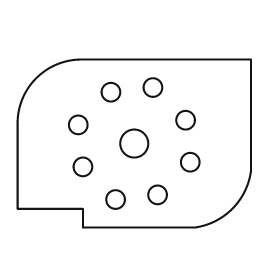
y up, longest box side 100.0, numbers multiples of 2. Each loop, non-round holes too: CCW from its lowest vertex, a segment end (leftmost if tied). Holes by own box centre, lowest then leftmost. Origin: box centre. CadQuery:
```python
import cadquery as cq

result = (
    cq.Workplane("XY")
    .moveTo(-22.0, -36.0)
    .lineTo(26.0, -36.0)
    .threePointArc((42.0, -28.0), (50.0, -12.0))
    .lineTo(50.0, 36.0)
    .lineTo(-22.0, 36.0)
    .threePointArc((-42.0, 28.0), (-50.0, 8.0))
    .lineTo(-50.0, -28.0)
    .lineTo(-22.0, -28.0)
    .close()
    .moveTo(-8.0, -24.0)
    .circle(4.0)
    .moveTo(10.0, -22.0)
    .circle(4.0)
    .moveTo(-22.0, -10.0)
    .circle(4.0)
    .moveTo(24.0, -8.0)
    .circle(4.0)
    .moveTo(0.0, 0.0)
    .circle(6.0)
    .moveTo(-24.0, 8.0)
    .circle(4.0)
    .moveTo(22.0, 10.0)
    .circle(4.0)
    .moveTo(-10.0, 22.0)
    .circle(4.0)
    .moveTo(8.0, 24.0)
    .circle(4.0)
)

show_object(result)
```